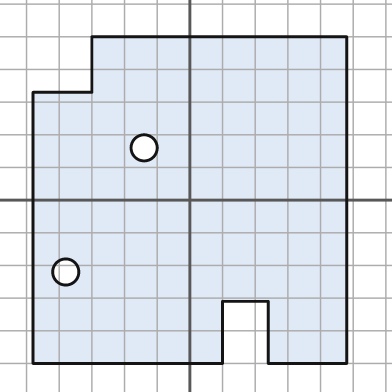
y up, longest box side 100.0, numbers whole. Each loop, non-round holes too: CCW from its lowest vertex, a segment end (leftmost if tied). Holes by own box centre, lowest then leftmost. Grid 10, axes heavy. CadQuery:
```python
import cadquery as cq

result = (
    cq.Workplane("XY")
    .moveTo(-48.0, -50.0)
    .lineTo(10.0, -50.0)
    .lineTo(10.0, -31.0)
    .lineTo(24.0, -31.0)
    .lineTo(24.0, -50.0)
    .lineTo(48.0, -50.0)
    .lineTo(48.0, 50.0)
    .lineTo(-30.0, 50.0)
    .lineTo(-30.0, 33.0)
    .lineTo(-48.0, 33.0)
    .close()
    .moveTo(-38.0, -22.0)
    .circle(4.0)
    .moveTo(-14.0, 16.0)
    .circle(4.0)
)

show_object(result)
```